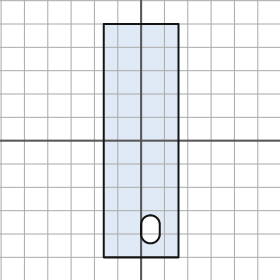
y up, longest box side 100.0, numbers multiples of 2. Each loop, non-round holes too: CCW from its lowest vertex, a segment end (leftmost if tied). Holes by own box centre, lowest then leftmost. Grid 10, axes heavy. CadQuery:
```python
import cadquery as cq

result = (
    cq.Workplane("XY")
    .moveTo(-16.0, -50.0)
    .lineTo(16.0, -50.0)
    .lineTo(16.0, 50.0)
    .lineTo(-16.0, 50.0)
    .close()
    .moveTo(0.0, -40.0)
    .threePointArc((4.0, -44.0), (8.0, -40.0))
    .lineTo(8.0, -36.0)
    .threePointArc((4.0, -32.0), (0.0, -36.0))
    .close()
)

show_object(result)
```